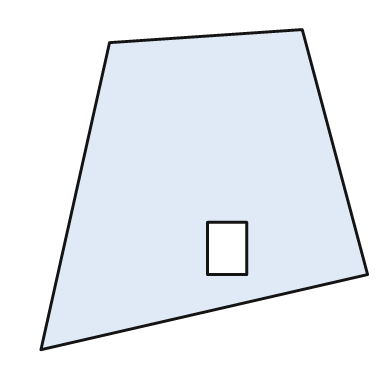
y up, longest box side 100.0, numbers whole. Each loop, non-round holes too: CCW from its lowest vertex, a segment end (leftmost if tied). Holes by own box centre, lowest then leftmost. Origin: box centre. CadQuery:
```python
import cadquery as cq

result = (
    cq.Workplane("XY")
    .moveTo(-50.0, -49.0)
    .lineTo(50.0, -26.0)
    .lineTo(30.0, 49.0)
    .lineTo(-29.0, 45.0)
    .close()
    .moveTo(1.0, -26.0)
    .lineTo(13.0, -26.0)
    .lineTo(13.0, -10.0)
    .lineTo(1.0, -10.0)
    .close()
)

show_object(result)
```